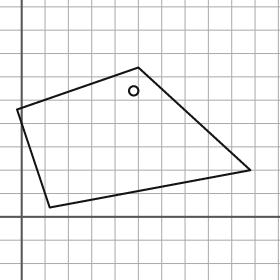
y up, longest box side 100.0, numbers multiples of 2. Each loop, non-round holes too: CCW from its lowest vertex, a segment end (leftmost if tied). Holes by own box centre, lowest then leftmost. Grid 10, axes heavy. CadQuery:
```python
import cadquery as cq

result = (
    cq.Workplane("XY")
    .moveTo(12.0, 4.0)
    .lineTo(98.0, 20.0)
    .lineTo(50.0, 64.0)
    .lineTo(-2.0, 46.0)
    .close()
    .moveTo(48.0, 54.0)
    .circle(2.0)
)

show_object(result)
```